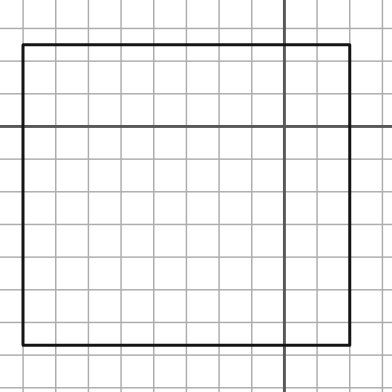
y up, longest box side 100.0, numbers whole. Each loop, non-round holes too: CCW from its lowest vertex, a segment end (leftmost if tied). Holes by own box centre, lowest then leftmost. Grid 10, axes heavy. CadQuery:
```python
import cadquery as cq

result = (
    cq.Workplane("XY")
    .moveTo(-80.0, -67.0)
    .lineTo(20.0, -67.0)
    .lineTo(20.0, 25.0)
    .lineTo(-80.0, 25.0)
    .close()
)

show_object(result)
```